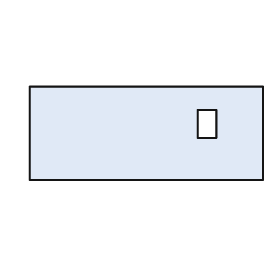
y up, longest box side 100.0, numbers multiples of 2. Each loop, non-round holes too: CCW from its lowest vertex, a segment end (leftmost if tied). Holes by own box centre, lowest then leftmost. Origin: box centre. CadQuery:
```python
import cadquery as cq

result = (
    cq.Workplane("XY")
    .moveTo(-50.0, -20.0)
    .lineTo(50.0, -20.0)
    .lineTo(50.0, 20.0)
    .lineTo(-50.0, 20.0)
    .close()
    .moveTo(22.0, -2.0)
    .lineTo(30.0, -2.0)
    .lineTo(30.0, 10.0)
    .lineTo(22.0, 10.0)
    .close()
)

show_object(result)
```